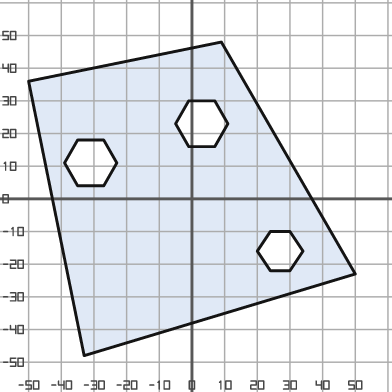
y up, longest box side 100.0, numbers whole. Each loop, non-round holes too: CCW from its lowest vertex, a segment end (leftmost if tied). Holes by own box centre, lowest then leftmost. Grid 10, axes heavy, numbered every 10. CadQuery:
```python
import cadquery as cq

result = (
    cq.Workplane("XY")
    .moveTo(-33.0, -48.0)
    .lineTo(50.0, -23.0)
    .lineTo(9.0, 48.0)
    .lineTo(-50.0, 36.0)
    .close()
    .moveTo(24.0, -22.0)
    .lineTo(30.0, -22.0)
    .lineTo(34.0, -16.0)
    .lineTo(30.0, -10.0)
    .lineTo(24.0, -10.0)
    .lineTo(20.0, -16.0)
    .close()
    .moveTo(-35.0, 4.0)
    .lineTo(-27.0, 4.0)
    .lineTo(-23.0, 11.0)
    .lineTo(-27.0, 18.0)
    .lineTo(-35.0, 18.0)
    .lineTo(-39.0, 11.0)
    .close()
    .moveTo(-1.0, 16.0)
    .lineTo(7.0, 16.0)
    .lineTo(11.0, 23.0)
    .lineTo(7.0, 30.0)
    .lineTo(-1.0, 30.0)
    .lineTo(-5.0, 23.0)
    .close()
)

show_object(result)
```